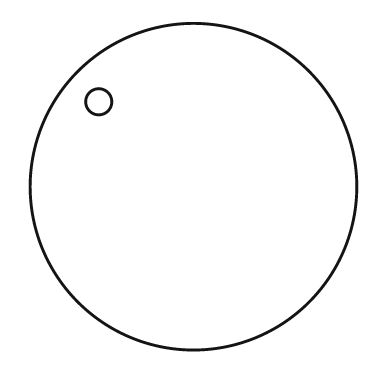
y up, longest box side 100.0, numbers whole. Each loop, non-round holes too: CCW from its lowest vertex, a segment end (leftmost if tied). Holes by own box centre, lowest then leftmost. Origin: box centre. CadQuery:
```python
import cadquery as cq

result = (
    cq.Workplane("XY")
    .moveTo(0.0, 0.0)
    .circle(50.0)
    .moveTo(-29.0, 26.0)
    .circle(4.0)
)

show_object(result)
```